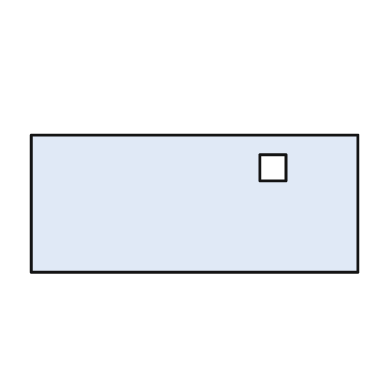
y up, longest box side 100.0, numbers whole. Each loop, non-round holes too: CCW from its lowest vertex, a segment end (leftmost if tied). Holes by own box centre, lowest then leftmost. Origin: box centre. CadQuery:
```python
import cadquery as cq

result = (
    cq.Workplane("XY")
    .moveTo(-50.0, -21.0)
    .lineTo(50.0, -21.0)
    .lineTo(50.0, 21.0)
    .lineTo(-50.0, 21.0)
    .close()
    .moveTo(20.0, 7.0)
    .lineTo(28.0, 7.0)
    .lineTo(28.0, 15.0)
    .lineTo(20.0, 15.0)
    .close()
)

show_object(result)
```